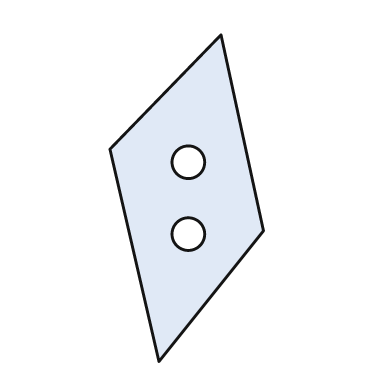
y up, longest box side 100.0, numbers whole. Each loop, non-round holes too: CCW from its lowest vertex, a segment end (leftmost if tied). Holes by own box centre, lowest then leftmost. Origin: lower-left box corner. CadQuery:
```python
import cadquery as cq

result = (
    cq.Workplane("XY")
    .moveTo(15.0, 0.0)
    .lineTo(47.0, 40.0)
    .lineTo(34.0, 100.0)
    .lineTo(0.0, 65.0)
    .close()
    .moveTo(24.0, 39.0)
    .circle(5.0)
    .moveTo(24.0, 61.0)
    .circle(5.0)
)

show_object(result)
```